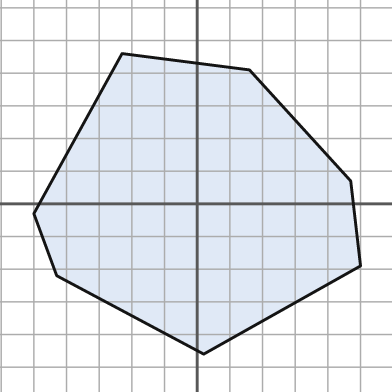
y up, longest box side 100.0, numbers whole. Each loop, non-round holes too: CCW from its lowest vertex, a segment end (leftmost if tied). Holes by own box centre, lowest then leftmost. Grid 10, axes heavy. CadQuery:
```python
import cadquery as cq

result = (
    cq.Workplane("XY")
    .moveTo(2.0, -46.0)
    .lineTo(50.0, -19.0)
    .lineTo(47.0, 7.0)
    .lineTo(16.0, 41.0)
    .lineTo(-23.0, 46.0)
    .lineTo(-50.0, -3.0)
    .lineTo(-43.0, -22.0)
    .close()
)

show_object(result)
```